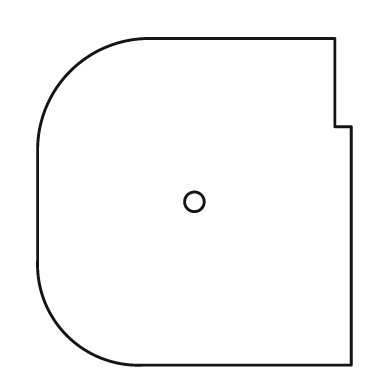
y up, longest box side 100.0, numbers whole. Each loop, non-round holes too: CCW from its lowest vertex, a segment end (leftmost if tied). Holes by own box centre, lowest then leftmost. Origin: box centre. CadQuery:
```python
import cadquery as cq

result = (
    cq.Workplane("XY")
    .moveTo(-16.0, -50.0)
    .lineTo(48.0, -50.0)
    .lineTo(48.0, 23.0)
    .lineTo(43.0, 23.0)
    .lineTo(43.0, 50.0)
    .lineTo(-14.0, 50.0)
    .threePointArc((-38.0, 40.0), (-48.0, 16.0))
    .lineTo(-48.0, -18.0)
    .threePointArc((-39.0, -41.0), (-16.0, -50.0))
    .close()
    .moveTo(0.0, 0.0)
    .circle(3.0)
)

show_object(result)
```